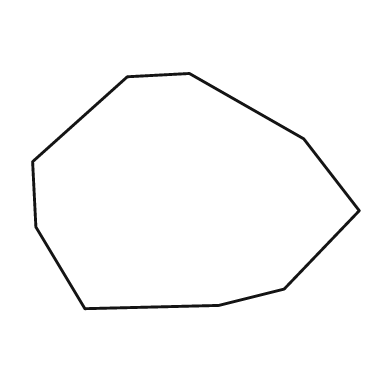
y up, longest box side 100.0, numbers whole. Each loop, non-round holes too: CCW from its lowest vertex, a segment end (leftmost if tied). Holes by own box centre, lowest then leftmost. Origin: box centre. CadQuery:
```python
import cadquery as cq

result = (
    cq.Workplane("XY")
    .moveTo(-34.0, -36.0)
    .lineTo(7.0, -35.0)
    .lineTo(27.0, -30.0)
    .lineTo(50.0, -6.0)
    .lineTo(33.0, 16.0)
    .lineTo(-2.0, 36.0)
    .lineTo(-21.0, 35.0)
    .lineTo(-50.0, 9.0)
    .lineTo(-49.0, -11.0)
    .close()
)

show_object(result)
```